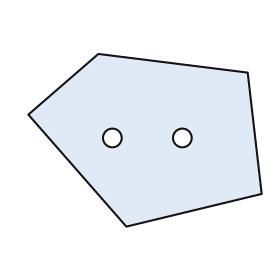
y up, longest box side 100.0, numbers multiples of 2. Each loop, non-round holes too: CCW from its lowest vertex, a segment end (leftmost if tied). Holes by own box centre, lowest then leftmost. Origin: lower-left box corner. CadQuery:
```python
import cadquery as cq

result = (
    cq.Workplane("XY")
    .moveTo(42.0, 0.0)
    .lineTo(100.0, 14.0)
    .lineTo(94.0, 66.0)
    .lineTo(30.0, 74.0)
    .lineTo(0.0, 48.0)
    .close()
    .moveTo(36.0, 38.0)
    .circle(4.0)
    .moveTo(66.0, 38.0)
    .circle(4.0)
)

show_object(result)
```